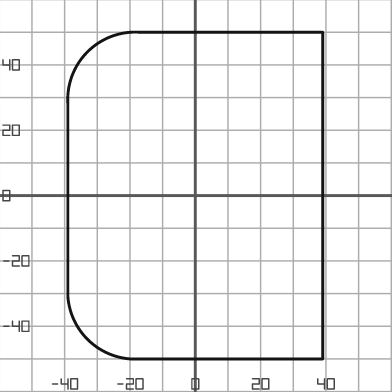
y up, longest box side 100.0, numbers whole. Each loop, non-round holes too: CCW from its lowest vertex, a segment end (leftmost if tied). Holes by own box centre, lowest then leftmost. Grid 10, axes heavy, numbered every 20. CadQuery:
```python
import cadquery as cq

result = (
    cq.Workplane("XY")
    .moveTo(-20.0, -50.0)
    .lineTo(39.0, -50.0)
    .lineTo(39.0, 50.0)
    .lineTo(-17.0, 50.0)
    .threePointArc((-33.0, 44.0), (-39.0, 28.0))
    .lineTo(-39.0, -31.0)
    .threePointArc((-33.0, -44.0), (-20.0, -50.0))
    .close()
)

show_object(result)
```